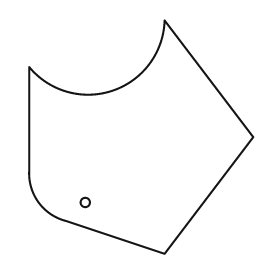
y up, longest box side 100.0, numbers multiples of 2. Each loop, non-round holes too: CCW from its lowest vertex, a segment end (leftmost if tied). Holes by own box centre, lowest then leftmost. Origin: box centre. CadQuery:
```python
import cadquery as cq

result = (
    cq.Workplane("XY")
    .moveTo(10.0, -50.0)
    .lineTo(48.0, 0.0)
    .lineTo(10.0, 50.0)
    .threePointArc((-12.0, 20.0), (-48.0, 30.0))
    .lineTo(-48.0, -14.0)
    .threePointArc((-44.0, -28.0), (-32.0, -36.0))
    .close()
    .moveTo(-24.0, -28.0)
    .circle(2.0)
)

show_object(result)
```